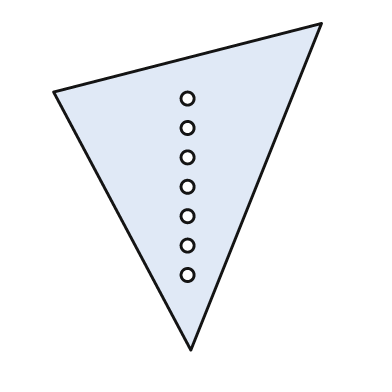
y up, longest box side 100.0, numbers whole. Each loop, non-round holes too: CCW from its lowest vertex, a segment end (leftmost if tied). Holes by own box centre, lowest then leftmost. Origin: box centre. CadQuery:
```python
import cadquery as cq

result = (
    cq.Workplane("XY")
    .moveTo(1.0, -50.0)
    .lineTo(41.0, 50.0)
    .lineTo(-41.0, 29.0)
    .close()
    .moveTo(0.0, -27.0)
    .circle(2.0)
    .moveTo(0.0, -18.0)
    .circle(2.0)
    .moveTo(0.0, -9.0)
    .circle(2.0)
    .moveTo(0.0, 0.0)
    .circle(2.0)
    .moveTo(0.0, 9.0)
    .circle(2.0)
    .moveTo(0.0, 18.0)
    .circle(2.0)
    .moveTo(0.0, 27.0)
    .circle(2.0)
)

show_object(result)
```